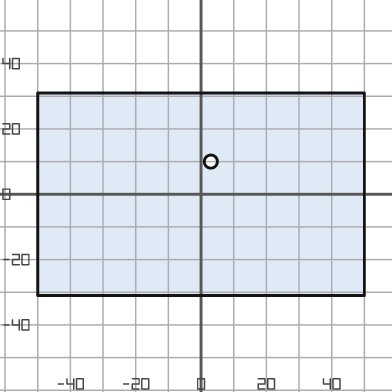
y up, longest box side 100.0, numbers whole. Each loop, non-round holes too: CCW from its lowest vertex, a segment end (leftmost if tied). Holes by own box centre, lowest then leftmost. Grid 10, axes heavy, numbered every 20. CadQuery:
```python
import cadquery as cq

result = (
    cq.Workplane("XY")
    .moveTo(-50.0, -31.0)
    .lineTo(50.0, -31.0)
    .lineTo(50.0, 31.0)
    .lineTo(-50.0, 31.0)
    .close()
    .moveTo(3.0, 10.0)
    .circle(2.0)
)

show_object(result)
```